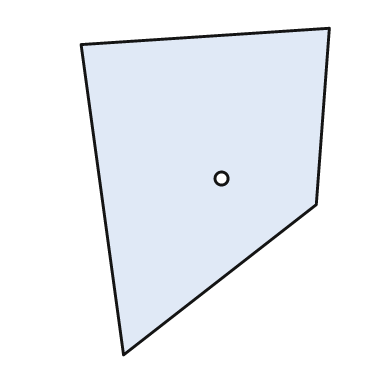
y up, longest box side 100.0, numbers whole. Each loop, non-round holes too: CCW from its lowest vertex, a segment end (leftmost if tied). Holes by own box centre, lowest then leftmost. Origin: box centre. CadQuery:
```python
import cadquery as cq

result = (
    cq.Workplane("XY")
    .moveTo(-25.0, -50.0)
    .lineTo(34.0, -4.0)
    .lineTo(38.0, 50.0)
    .lineTo(-38.0, 45.0)
    .close()
    .moveTo(5.0, 4.0)
    .circle(2.0)
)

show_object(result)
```